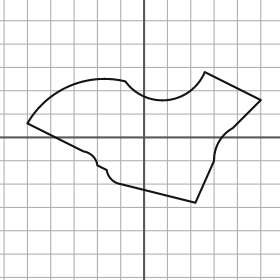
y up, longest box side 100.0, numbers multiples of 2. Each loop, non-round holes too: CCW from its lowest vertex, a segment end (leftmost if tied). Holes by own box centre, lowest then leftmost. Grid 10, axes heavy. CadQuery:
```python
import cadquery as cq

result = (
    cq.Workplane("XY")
    .moveTo(22.0, -28.0)
    .lineTo(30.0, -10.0)
    .threePointArc((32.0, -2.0), (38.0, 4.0))
    .lineTo(50.0, 16.0)
    .lineTo(26.0, 28.0)
    .threePointArc((10.0, 16.0), (-8.0, 24.0))
    .threePointArc((-32.0, 22.0), (-50.0, 6.0))
    .lineTo(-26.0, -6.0)
    .threePointArc((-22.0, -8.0), (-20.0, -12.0))
    .lineTo(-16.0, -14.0)
    .threePointArc((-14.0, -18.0), (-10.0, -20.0))
    .close()
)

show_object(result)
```